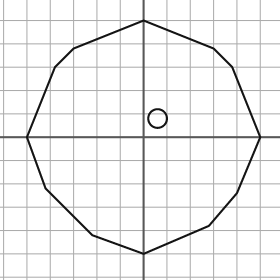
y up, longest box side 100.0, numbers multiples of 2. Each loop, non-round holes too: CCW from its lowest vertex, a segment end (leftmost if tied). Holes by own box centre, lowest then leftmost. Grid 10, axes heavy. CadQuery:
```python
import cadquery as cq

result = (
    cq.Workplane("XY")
    .moveTo(0.0, -50.0)
    .lineTo(28.0, -38.0)
    .lineTo(40.0, -24.0)
    .lineTo(50.0, 0.0)
    .lineTo(38.0, 30.0)
    .lineTo(30.0, 38.0)
    .lineTo(0.0, 50.0)
    .lineTo(-30.0, 38.0)
    .lineTo(-38.0, 30.0)
    .lineTo(-50.0, 0.0)
    .lineTo(-42.0, -22.0)
    .lineTo(-22.0, -42.0)
    .close()
    .moveTo(6.0, 8.0)
    .circle(4.0)
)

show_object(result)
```